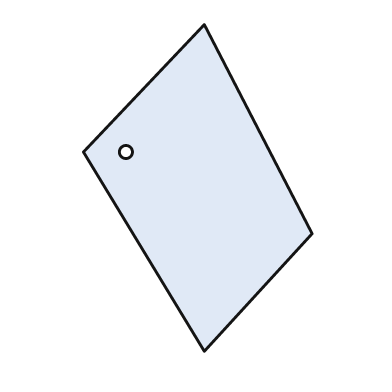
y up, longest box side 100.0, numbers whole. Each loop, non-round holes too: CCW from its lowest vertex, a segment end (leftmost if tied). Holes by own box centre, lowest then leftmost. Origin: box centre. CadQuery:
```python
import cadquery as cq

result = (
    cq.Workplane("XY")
    .moveTo(2.0, -50.0)
    .lineTo(35.0, -14.0)
    .lineTo(2.0, 50.0)
    .lineTo(-35.0, 11.0)
    .close()
    .moveTo(-22.0, 11.0)
    .circle(2.0)
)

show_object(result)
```